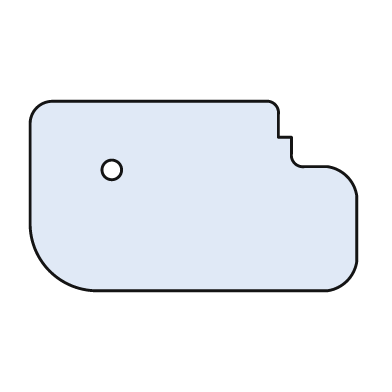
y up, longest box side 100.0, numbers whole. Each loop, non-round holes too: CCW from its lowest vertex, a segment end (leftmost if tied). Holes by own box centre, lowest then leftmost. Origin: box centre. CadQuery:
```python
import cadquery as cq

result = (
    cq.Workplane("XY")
    .moveTo(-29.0, -29.0)
    .lineTo(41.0, -29.0)
    .threePointArc((47.0, -26.0), (50.0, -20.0))
    .lineTo(50.0, 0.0)
    .threePointArc((47.0, 6.0), (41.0, 9.0))
    .lineTo(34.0, 9.0)
    .threePointArc((31.0, 10.0), (30.0, 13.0))
    .lineTo(30.0, 18.0)
    .lineTo(26.0, 18.0)
    .lineTo(26.0, 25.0)
    .threePointArc((25.0, 28.0), (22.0, 29.0))
    .lineTo(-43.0, 29.0)
    .threePointArc((-48.0, 27.0), (-50.0, 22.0))
    .lineTo(-50.0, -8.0)
    .threePointArc((-44.0, -23.0), (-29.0, -29.0))
    .close()
    .moveTo(-25.0, 8.0)
    .circle(3.0)
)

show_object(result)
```